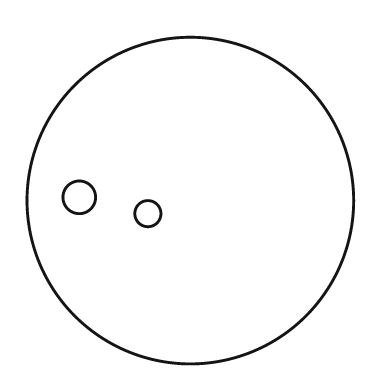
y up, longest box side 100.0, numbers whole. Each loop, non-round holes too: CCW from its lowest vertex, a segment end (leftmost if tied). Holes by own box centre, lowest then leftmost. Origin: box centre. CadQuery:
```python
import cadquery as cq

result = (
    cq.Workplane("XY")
    .moveTo(0.0, 0.0)
    .circle(50.0)
    .moveTo(-13.0, -4.0)
    .circle(4.0)
    .moveTo(-34.0, 1.0)
    .circle(5.0)
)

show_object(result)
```